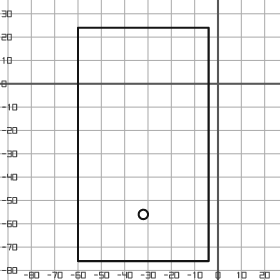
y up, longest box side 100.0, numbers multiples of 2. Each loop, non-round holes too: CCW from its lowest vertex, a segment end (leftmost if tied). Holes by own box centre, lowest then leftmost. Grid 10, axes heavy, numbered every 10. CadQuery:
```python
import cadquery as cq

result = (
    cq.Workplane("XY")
    .moveTo(-60.0, -76.0)
    .lineTo(-4.0, -76.0)
    .lineTo(-4.0, 24.0)
    .lineTo(-60.0, 24.0)
    .close()
    .moveTo(-32.0, -56.0)
    .circle(2.0)
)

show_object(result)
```